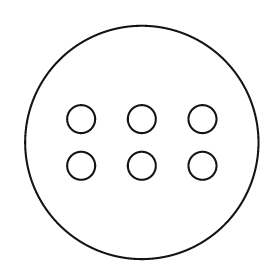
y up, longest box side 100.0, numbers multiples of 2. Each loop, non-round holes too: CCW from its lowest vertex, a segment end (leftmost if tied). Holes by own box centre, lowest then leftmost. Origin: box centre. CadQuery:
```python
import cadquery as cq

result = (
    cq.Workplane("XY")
    .moveTo(0.0, 0.0)
    .circle(50.0)
    .moveTo(-26.0, -10.0)
    .circle(6.0)
    .moveTo(0.0, -10.0)
    .circle(6.0)
    .moveTo(26.0, -10.0)
    .circle(6.0)
    .moveTo(-26.0, 10.0)
    .circle(6.0)
    .moveTo(0.0, 10.0)
    .circle(6.0)
    .moveTo(26.0, 10.0)
    .circle(6.0)
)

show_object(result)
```